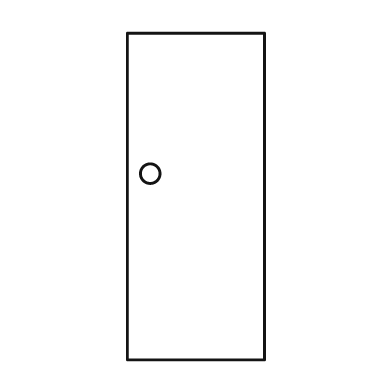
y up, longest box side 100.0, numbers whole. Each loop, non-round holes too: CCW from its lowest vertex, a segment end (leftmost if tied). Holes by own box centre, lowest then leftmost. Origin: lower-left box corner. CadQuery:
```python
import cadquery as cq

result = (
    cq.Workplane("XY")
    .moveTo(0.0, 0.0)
    .lineTo(42.0, 0.0)
    .lineTo(42.0, 100.0)
    .lineTo(0.0, 100.0)
    .close()
    .moveTo(7.0, 57.0)
    .circle(3.0)
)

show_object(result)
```